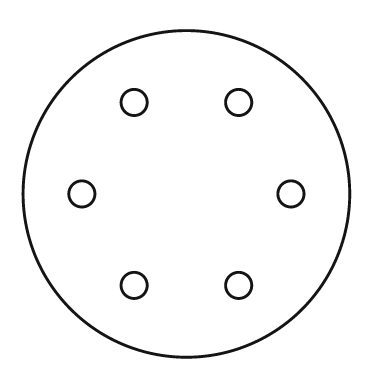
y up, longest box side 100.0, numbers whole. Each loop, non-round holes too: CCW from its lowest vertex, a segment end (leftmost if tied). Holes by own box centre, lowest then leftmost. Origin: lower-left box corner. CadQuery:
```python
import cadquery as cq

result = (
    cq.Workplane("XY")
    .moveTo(50.0, 50.0)
    .circle(50.0)
    .moveTo(34.0, 22.0)
    .circle(4.0)
    .moveTo(66.0, 22.0)
    .circle(4.0)
    .moveTo(18.0, 50.0)
    .circle(4.0)
    .moveTo(82.0, 50.0)
    .circle(4.0)
    .moveTo(34.0, 78.0)
    .circle(4.0)
    .moveTo(66.0, 78.0)
    .circle(4.0)
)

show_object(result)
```